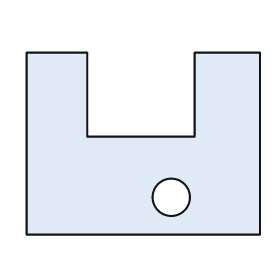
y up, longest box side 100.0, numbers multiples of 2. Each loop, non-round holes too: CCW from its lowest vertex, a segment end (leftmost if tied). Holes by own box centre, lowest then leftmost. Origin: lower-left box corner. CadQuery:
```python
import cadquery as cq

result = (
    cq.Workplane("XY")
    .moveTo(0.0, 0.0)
    .lineTo(100.0, 0.0)
    .lineTo(100.0, 78.0)
    .lineTo(72.0, 78.0)
    .lineTo(72.0, 42.0)
    .lineTo(26.0, 42.0)
    .lineTo(26.0, 78.0)
    .lineTo(0.0, 78.0)
    .close()
    .moveTo(62.0, 16.0)
    .circle(8.0)
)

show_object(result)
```